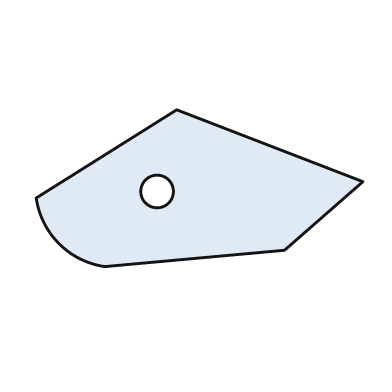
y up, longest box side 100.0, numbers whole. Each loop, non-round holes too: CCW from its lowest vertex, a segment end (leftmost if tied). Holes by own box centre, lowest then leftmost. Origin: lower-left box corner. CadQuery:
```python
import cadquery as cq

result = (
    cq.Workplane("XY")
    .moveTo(21.0, 0.0)
    .lineTo(76.0, 5.0)
    .lineTo(100.0, 26.0)
    .lineTo(43.0, 48.0)
    .lineTo(0.0, 21.0)
    .threePointArc((7.0, 7.0), (21.0, 0.0))
    .close()
    .moveTo(37.0, 23.0)
    .circle(5.0)
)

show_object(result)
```